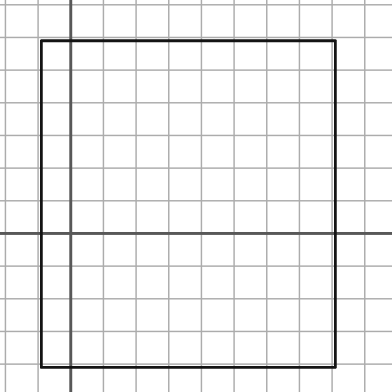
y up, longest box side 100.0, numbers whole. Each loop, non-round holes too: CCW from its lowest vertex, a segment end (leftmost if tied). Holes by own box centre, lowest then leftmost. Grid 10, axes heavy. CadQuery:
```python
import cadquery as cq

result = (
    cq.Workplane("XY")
    .moveTo(-9.0, -41.0)
    .lineTo(81.0, -41.0)
    .lineTo(81.0, 59.0)
    .lineTo(-9.0, 59.0)
    .close()
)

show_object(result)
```